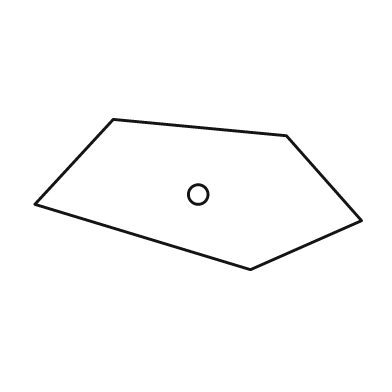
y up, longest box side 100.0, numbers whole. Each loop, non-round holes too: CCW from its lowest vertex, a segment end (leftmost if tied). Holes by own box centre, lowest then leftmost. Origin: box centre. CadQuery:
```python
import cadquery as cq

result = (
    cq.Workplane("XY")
    .moveTo(16.0, -23.0)
    .lineTo(50.0, -8.0)
    .lineTo(27.0, 18.0)
    .lineTo(-26.0, 23.0)
    .lineTo(-50.0, -3.0)
    .close()
    .moveTo(0.0, 0.0)
    .circle(3.0)
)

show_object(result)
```